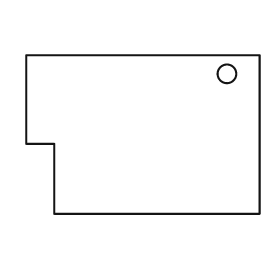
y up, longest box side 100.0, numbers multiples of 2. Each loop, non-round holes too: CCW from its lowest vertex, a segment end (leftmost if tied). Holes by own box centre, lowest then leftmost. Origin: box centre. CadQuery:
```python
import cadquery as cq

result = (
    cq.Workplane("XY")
    .moveTo(-38.0, -34.0)
    .lineTo(50.0, -34.0)
    .lineTo(50.0, 34.0)
    .lineTo(-50.0, 34.0)
    .lineTo(-50.0, -4.0)
    .lineTo(-38.0, -4.0)
    .close()
    .moveTo(36.0, 26.0)
    .circle(4.0)
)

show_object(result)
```